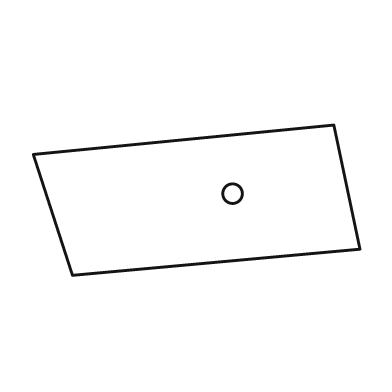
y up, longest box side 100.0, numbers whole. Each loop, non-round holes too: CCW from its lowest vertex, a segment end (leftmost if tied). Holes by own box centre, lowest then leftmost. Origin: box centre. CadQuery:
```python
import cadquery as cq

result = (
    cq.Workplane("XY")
    .moveTo(-38.0, -23.0)
    .lineTo(50.0, -15.0)
    .lineTo(42.0, 23.0)
    .lineTo(-50.0, 14.0)
    .close()
    .moveTo(11.0, 2.0)
    .circle(3.0)
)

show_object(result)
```